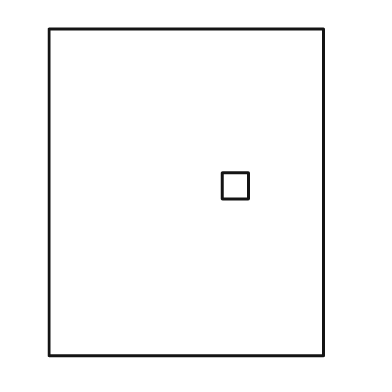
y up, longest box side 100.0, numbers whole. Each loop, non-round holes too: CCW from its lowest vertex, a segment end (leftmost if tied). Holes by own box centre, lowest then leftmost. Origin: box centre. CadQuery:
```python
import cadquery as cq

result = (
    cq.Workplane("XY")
    .moveTo(-42.0, -50.0)
    .lineTo(42.0, -50.0)
    .lineTo(42.0, 50.0)
    .lineTo(-42.0, 50.0)
    .close()
    .moveTo(11.0, -2.0)
    .lineTo(19.0, -2.0)
    .lineTo(19.0, 6.0)
    .lineTo(11.0, 6.0)
    .close()
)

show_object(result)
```